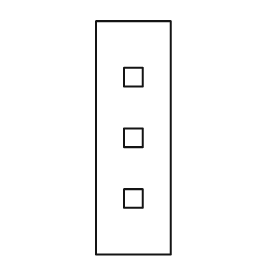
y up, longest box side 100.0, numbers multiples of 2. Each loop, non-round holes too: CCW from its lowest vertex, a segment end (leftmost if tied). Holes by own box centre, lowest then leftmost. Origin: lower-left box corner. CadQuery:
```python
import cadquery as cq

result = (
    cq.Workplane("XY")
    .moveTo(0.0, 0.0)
    .lineTo(32.0, 0.0)
    .lineTo(32.0, 100.0)
    .lineTo(0.0, 100.0)
    .close()
    .moveTo(12.0, 20.0)
    .lineTo(20.0, 20.0)
    .lineTo(20.0, 28.0)
    .lineTo(12.0, 28.0)
    .close()
    .moveTo(12.0, 46.0)
    .lineTo(20.0, 46.0)
    .lineTo(20.0, 54.0)
    .lineTo(12.0, 54.0)
    .close()
    .moveTo(12.0, 72.0)
    .lineTo(20.0, 72.0)
    .lineTo(20.0, 80.0)
    .lineTo(12.0, 80.0)
    .close()
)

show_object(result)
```